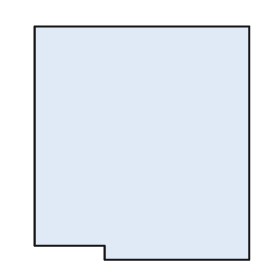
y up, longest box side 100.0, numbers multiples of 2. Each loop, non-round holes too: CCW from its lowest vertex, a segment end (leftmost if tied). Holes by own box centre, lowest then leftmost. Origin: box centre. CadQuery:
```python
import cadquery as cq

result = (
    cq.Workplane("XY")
    .moveTo(-16.0, -50.0)
    .lineTo(46.0, -50.0)
    .lineTo(46.0, 50.0)
    .lineTo(-46.0, 50.0)
    .lineTo(-46.0, -44.0)
    .lineTo(-16.0, -44.0)
    .close()
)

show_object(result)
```